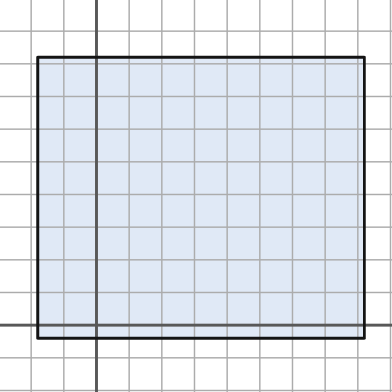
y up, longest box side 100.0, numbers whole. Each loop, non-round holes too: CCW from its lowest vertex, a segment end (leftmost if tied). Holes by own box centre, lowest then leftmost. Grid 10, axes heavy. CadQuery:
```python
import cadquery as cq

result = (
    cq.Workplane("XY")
    .moveTo(-18.0, -4.0)
    .lineTo(82.0, -4.0)
    .lineTo(82.0, 82.0)
    .lineTo(-18.0, 82.0)
    .close()
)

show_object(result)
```